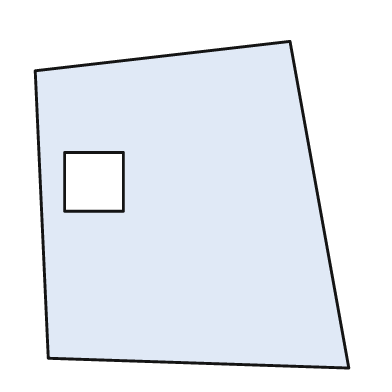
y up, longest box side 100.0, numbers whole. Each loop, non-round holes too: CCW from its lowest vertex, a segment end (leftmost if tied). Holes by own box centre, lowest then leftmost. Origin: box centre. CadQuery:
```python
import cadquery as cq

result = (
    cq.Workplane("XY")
    .moveTo(48.0, -50.0)
    .lineTo(30.0, 50.0)
    .lineTo(-48.0, 41.0)
    .lineTo(-44.0, -47.0)
    .close()
    .moveTo(-39.0, -2.0)
    .lineTo(-21.0, -2.0)
    .lineTo(-21.0, 16.0)
    .lineTo(-39.0, 16.0)
    .close()
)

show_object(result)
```